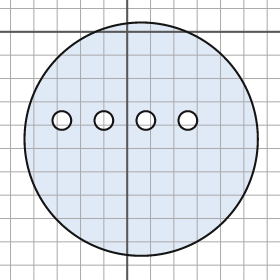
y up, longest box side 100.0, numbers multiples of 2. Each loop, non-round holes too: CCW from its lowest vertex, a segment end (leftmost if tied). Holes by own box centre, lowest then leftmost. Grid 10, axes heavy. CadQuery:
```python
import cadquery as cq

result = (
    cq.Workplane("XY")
    .moveTo(6.0, -46.0)
    .circle(50.0)
    .moveTo(-28.0, -38.0)
    .circle(4.0)
    .moveTo(-10.0, -38.0)
    .circle(4.0)
    .moveTo(8.0, -38.0)
    .circle(4.0)
    .moveTo(26.0, -38.0)
    .circle(4.0)
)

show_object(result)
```